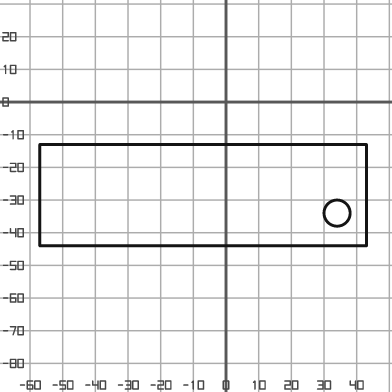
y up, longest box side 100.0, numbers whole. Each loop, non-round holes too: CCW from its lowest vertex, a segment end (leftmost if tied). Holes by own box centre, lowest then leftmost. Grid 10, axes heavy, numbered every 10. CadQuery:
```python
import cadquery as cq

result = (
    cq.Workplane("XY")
    .moveTo(-57.0, -44.0)
    .lineTo(43.0, -44.0)
    .lineTo(43.0, -13.0)
    .lineTo(-57.0, -13.0)
    .close()
    .moveTo(34.0, -34.0)
    .circle(4.0)
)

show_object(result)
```